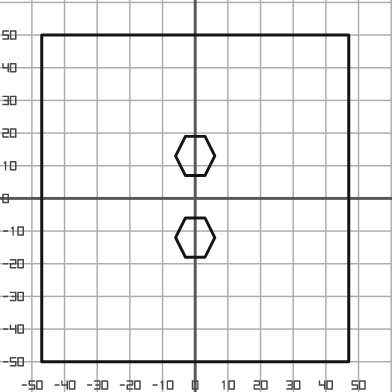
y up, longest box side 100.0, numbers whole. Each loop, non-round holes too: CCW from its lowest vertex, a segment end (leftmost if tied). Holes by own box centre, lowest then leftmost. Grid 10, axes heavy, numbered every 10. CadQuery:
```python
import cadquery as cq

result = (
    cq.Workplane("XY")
    .moveTo(-47.0, -50.0)
    .lineTo(47.0, -50.0)
    .lineTo(47.0, 50.0)
    .lineTo(-47.0, 50.0)
    .close()
    .moveTo(-3.0, -18.0)
    .lineTo(3.0, -18.0)
    .lineTo(6.0, -12.0)
    .lineTo(3.0, -6.0)
    .lineTo(-3.0, -6.0)
    .lineTo(-6.0, -12.0)
    .close()
    .moveTo(-3.0, 7.0)
    .lineTo(3.0, 7.0)
    .lineTo(6.0, 13.0)
    .lineTo(3.0, 19.0)
    .lineTo(-3.0, 19.0)
    .lineTo(-6.0, 13.0)
    .close()
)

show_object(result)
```